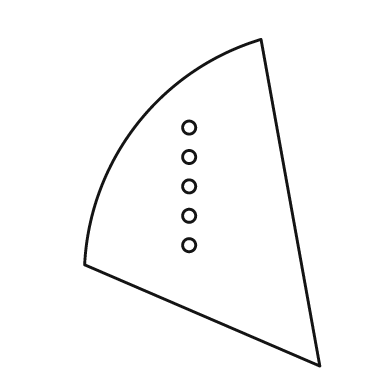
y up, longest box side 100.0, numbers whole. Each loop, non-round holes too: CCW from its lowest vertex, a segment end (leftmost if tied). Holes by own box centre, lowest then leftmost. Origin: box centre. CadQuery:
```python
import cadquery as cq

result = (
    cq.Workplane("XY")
    .moveTo(36.0, -50.0)
    .lineTo(18.0, 50.0)
    .threePointArc((-20.0, 24.0), (-36.0, -19.0))
    .close()
    .moveTo(-4.0, -13.0)
    .circle(2.0)
    .moveTo(-4.0, -4.0)
    .circle(2.0)
    .moveTo(-4.0, 5.0)
    .circle(2.0)
    .moveTo(-4.0, 14.0)
    .circle(2.0)
    .moveTo(-4.0, 23.0)
    .circle(2.0)
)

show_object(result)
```